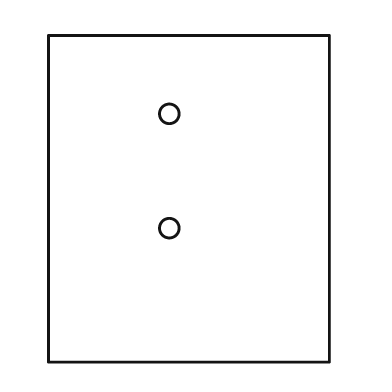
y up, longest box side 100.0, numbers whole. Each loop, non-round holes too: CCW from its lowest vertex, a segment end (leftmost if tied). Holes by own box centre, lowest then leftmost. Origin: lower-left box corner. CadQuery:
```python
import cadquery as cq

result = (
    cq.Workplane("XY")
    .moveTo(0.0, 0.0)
    .lineTo(86.0, 0.0)
    .lineTo(86.0, 100.0)
    .lineTo(0.0, 100.0)
    .close()
    .moveTo(37.0, 41.0)
    .circle(3.0)
    .moveTo(37.0, 76.0)
    .circle(3.0)
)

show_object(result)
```